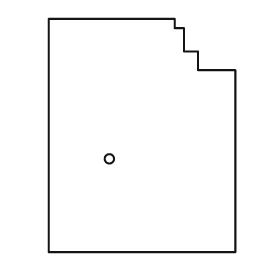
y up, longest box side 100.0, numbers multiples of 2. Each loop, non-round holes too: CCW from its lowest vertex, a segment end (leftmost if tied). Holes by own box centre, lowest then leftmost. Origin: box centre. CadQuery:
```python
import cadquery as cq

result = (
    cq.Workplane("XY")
    .moveTo(-40.0, -50.0)
    .lineTo(40.0, -50.0)
    .lineTo(40.0, 28.0)
    .lineTo(24.0, 28.0)
    .lineTo(24.0, 36.0)
    .lineTo(18.0, 36.0)
    .lineTo(18.0, 46.0)
    .lineTo(14.0, 46.0)
    .lineTo(14.0, 50.0)
    .lineTo(-40.0, 50.0)
    .close()
    .moveTo(-14.0, -10.0)
    .circle(2.0)
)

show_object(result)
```